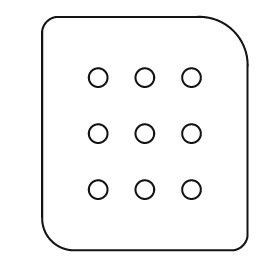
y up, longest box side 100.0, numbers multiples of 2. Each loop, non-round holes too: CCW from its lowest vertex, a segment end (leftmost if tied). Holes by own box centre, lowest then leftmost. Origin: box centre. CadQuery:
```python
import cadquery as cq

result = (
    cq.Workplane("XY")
    .moveTo(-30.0, -50.0)
    .lineTo(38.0, -50.0)
    .threePointArc((42.0, -48.0), (44.0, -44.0))
    .lineTo(44.0, 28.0)
    .threePointArc((38.0, 44.0), (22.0, 50.0))
    .lineTo(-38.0, 50.0)
    .threePointArc((-42.0, 48.0), (-44.0, 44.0))
    .lineTo(-44.0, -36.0)
    .threePointArc((-40.0, -46.0), (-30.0, -50.0))
    .close()
    .moveTo(-20.0, -24.0)
    .circle(4.0)
    .moveTo(0.0, -24.0)
    .circle(4.0)
    .moveTo(20.0, -24.0)
    .circle(4.0)
    .moveTo(-20.0, 0.0)
    .circle(4.0)
    .moveTo(0.0, 0.0)
    .circle(4.0)
    .moveTo(20.0, 0.0)
    .circle(4.0)
    .moveTo(-20.0, 24.0)
    .circle(4.0)
    .moveTo(0.0, 24.0)
    .circle(4.0)
    .moveTo(20.0, 24.0)
    .circle(4.0)
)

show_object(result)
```